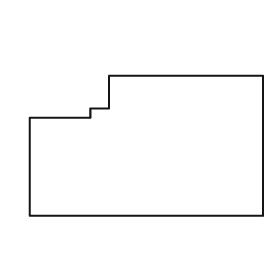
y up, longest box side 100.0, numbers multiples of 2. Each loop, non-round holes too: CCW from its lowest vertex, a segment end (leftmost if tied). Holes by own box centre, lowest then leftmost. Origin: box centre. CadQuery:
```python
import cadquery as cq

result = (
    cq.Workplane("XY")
    .moveTo(-50.0, -30.0)
    .lineTo(50.0, -30.0)
    .lineTo(50.0, 30.0)
    .lineTo(-16.0, 30.0)
    .lineTo(-16.0, 16.0)
    .lineTo(-24.0, 16.0)
    .lineTo(-24.0, 12.0)
    .lineTo(-50.0, 12.0)
    .close()
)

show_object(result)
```